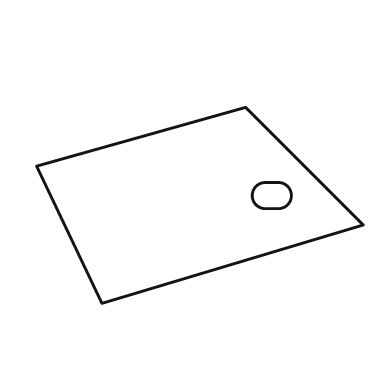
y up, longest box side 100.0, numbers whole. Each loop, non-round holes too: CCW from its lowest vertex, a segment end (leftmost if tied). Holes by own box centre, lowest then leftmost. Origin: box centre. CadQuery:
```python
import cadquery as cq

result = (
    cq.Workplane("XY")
    .moveTo(-30.0, -30.0)
    .lineTo(50.0, -6.0)
    .lineTo(14.0, 30.0)
    .lineTo(-50.0, 12.0)
    .close()
    .moveTo(20.0, -1.0)
    .lineTo(24.0, -1.0)
    .threePointArc((28.0, 3.0), (24.0, 7.0))
    .lineTo(20.0, 7.0)
    .threePointArc((16.0, 3.0), (20.0, -1.0))
    .close()
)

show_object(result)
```